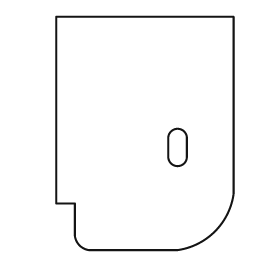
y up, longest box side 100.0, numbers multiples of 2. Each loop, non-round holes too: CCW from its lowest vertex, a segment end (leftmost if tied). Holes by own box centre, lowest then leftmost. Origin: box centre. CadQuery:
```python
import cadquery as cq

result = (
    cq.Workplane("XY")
    .moveTo(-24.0, -50.0)
    .lineTo(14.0, -50.0)
    .threePointArc((30.0, -42.0), (38.0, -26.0))
    .lineTo(38.0, 50.0)
    .lineTo(-38.0, 50.0)
    .lineTo(-38.0, -30.0)
    .lineTo(-30.0, -30.0)
    .lineTo(-30.0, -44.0)
    .threePointArc((-28.0, -48.0), (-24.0, -50.0))
    .close()
    .moveTo(10.0, -10.0)
    .threePointArc((14.0, -14.0), (18.0, -10.0))
    .lineTo(18.0, -2.0)
    .threePointArc((14.0, 2.0), (10.0, -2.0))
    .close()
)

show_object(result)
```